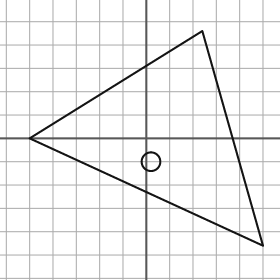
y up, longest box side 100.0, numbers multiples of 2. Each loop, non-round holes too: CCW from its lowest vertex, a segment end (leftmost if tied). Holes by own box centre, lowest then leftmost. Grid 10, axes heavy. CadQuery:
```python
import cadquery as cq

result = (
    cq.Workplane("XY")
    .moveTo(50.0, -46.0)
    .lineTo(24.0, 46.0)
    .lineTo(-50.0, 0.0)
    .close()
    .moveTo(2.0, -10.0)
    .circle(4.0)
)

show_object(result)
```